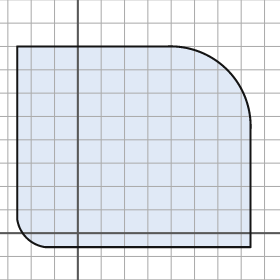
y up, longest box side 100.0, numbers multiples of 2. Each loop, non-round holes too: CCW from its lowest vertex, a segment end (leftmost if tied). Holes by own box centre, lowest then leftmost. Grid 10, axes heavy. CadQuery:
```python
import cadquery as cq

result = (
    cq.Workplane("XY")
    .moveTo(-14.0, -6.0)
    .lineTo(74.0, -6.0)
    .lineTo(74.0, 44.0)
    .threePointArc((64.0, 70.0), (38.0, 80.0))
    .lineTo(-26.0, 80.0)
    .lineTo(-26.0, 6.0)
    .threePointArc((-22.0, -2.0), (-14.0, -6.0))
    .close()
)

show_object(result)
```